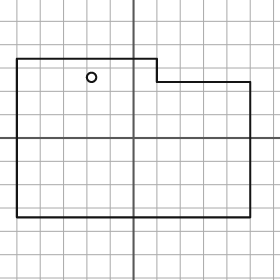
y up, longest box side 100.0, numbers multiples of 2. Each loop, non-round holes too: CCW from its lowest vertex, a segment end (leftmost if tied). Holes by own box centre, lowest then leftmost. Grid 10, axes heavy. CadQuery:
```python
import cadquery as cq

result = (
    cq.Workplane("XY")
    .moveTo(-50.0, -34.0)
    .lineTo(50.0, -34.0)
    .lineTo(50.0, 24.0)
    .lineTo(10.0, 24.0)
    .lineTo(10.0, 34.0)
    .lineTo(-50.0, 34.0)
    .close()
    .moveTo(-18.0, 26.0)
    .circle(2.0)
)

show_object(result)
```